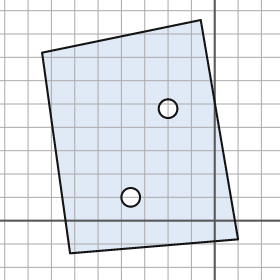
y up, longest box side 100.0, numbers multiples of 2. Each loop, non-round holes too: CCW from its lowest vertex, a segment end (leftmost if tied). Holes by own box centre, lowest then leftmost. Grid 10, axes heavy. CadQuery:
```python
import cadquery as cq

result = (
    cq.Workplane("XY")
    .moveTo(-62.0, -14.0)
    .lineTo(10.0, -8.0)
    .lineTo(-6.0, 86.0)
    .lineTo(-74.0, 72.0)
    .close()
    .moveTo(-36.0, 10.0)
    .circle(4.0)
    .moveTo(-20.0, 48.0)
    .circle(4.0)
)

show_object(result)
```